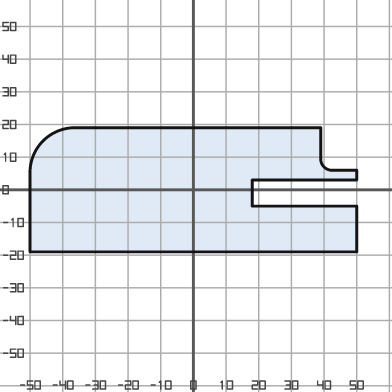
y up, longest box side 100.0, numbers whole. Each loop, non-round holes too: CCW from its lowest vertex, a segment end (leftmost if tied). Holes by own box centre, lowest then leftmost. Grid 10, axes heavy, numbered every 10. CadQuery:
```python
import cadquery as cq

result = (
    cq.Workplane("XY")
    .moveTo(-50.0, -19.0)
    .lineTo(50.0, -19.0)
    .lineTo(50.0, -5.0)
    .lineTo(18.0, -5.0)
    .lineTo(18.0, 3.0)
    .lineTo(50.0, 3.0)
    .lineTo(50.0, 6.0)
    .lineTo(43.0, 6.0)
    .threePointArc((40.0, 7.0), (39.0, 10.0))
    .lineTo(39.0, 19.0)
    .lineTo(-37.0, 19.0)
    .threePointArc((-46.0, 15.0), (-50.0, 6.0))
    .close()
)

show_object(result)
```